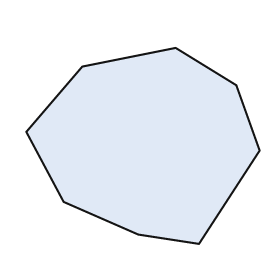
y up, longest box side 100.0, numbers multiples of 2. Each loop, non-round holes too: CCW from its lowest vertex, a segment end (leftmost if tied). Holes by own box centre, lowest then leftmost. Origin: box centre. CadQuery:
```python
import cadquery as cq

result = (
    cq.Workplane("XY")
    .moveTo(24.0, -42.0)
    .lineTo(50.0, -2.0)
    .lineTo(40.0, 26.0)
    .lineTo(14.0, 42.0)
    .lineTo(-26.0, 34.0)
    .lineTo(-50.0, 6.0)
    .lineTo(-34.0, -24.0)
    .lineTo(-2.0, -38.0)
    .close()
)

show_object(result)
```